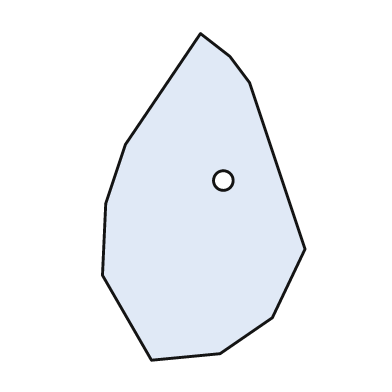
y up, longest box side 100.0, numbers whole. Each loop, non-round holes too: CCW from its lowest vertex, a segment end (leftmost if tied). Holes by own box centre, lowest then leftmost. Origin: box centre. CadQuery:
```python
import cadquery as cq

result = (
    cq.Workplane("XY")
    .moveTo(-16.0, -50.0)
    .lineTo(5.0, -48.0)
    .lineTo(21.0, -37.0)
    .lineTo(31.0, -16.0)
    .lineTo(14.0, 35.0)
    .lineTo(8.0, 43.0)
    .lineTo(-1.0, 50.0)
    .lineTo(-24.0, 16.0)
    .lineTo(-30.0, -2.0)
    .lineTo(-31.0, -24.0)
    .close()
    .moveTo(6.0, 5.0)
    .circle(3.0)
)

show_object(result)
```